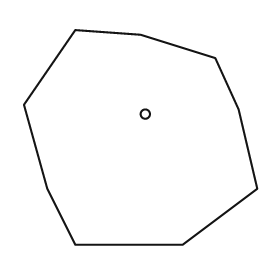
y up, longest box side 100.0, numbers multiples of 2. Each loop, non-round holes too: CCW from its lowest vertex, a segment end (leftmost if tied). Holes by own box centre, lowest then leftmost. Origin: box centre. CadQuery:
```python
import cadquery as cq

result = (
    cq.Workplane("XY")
    .moveTo(-28.0, -46.0)
    .lineTo(18.0, -46.0)
    .lineTo(50.0, -22.0)
    .lineTo(42.0, 12.0)
    .lineTo(32.0, 34.0)
    .lineTo(0.0, 44.0)
    .lineTo(-28.0, 46.0)
    .lineTo(-50.0, 14.0)
    .lineTo(-40.0, -22.0)
    .close()
    .moveTo(2.0, 10.0)
    .circle(2.0)
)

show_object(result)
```